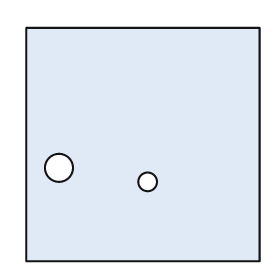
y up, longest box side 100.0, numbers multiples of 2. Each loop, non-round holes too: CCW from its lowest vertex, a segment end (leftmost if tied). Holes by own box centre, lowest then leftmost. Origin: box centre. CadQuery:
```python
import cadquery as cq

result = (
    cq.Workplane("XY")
    .moveTo(-50.0, -50.0)
    .lineTo(50.0, -50.0)
    .lineTo(50.0, 50.0)
    .lineTo(-50.0, 50.0)
    .close()
    .moveTo(2.0, -16.0)
    .circle(4.0)
    .moveTo(-36.0, -10.0)
    .circle(6.0)
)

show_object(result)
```